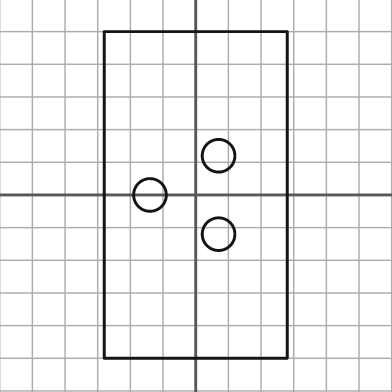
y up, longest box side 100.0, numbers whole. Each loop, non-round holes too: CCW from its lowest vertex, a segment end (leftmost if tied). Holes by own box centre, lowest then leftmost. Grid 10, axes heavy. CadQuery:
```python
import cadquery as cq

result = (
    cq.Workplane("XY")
    .moveTo(-28.0, -50.0)
    .lineTo(28.0, -50.0)
    .lineTo(28.0, 50.0)
    .lineTo(-28.0, 50.0)
    .close()
    .moveTo(7.0, -12.0)
    .circle(5.0)
    .moveTo(-14.0, 0.0)
    .circle(5.0)
    .moveTo(7.0, 12.0)
    .circle(5.0)
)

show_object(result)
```